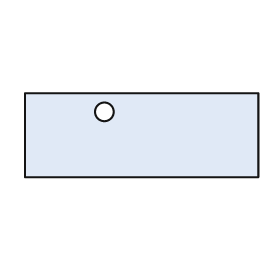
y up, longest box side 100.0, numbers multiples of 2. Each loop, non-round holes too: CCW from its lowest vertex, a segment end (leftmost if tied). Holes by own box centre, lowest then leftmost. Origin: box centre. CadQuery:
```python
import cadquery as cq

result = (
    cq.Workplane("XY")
    .moveTo(-50.0, -18.0)
    .lineTo(50.0, -18.0)
    .lineTo(50.0, 18.0)
    .lineTo(-50.0, 18.0)
    .close()
    .moveTo(-16.0, 10.0)
    .circle(4.0)
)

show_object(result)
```